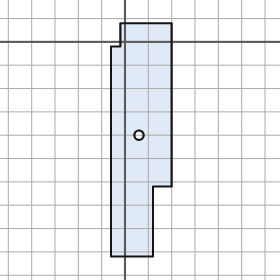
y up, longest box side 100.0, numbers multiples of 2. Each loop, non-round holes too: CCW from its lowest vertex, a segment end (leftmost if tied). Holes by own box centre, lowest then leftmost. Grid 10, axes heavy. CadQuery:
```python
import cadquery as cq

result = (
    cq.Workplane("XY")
    .moveTo(-6.0, -92.0)
    .lineTo(12.0, -92.0)
    .lineTo(12.0, -62.0)
    .lineTo(20.0, -62.0)
    .lineTo(20.0, 8.0)
    .lineTo(-2.0, 8.0)
    .lineTo(-2.0, -2.0)
    .lineTo(-6.0, -2.0)
    .close()
    .moveTo(6.0, -40.0)
    .circle(2.0)
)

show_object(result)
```